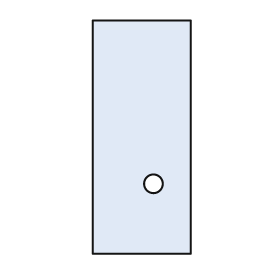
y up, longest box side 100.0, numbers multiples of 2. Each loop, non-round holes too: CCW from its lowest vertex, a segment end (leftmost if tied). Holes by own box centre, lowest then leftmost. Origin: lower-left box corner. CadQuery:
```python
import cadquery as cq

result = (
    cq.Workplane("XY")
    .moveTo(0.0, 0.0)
    .lineTo(42.0, 0.0)
    .lineTo(42.0, 100.0)
    .lineTo(0.0, 100.0)
    .close()
    .moveTo(26.0, 30.0)
    .circle(4.0)
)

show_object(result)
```